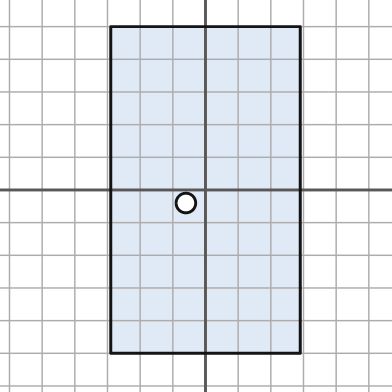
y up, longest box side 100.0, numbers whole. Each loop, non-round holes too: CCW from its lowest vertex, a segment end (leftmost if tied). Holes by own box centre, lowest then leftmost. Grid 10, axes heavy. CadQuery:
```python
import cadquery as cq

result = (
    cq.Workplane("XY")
    .moveTo(-29.0, -50.0)
    .lineTo(29.0, -50.0)
    .lineTo(29.0, 50.0)
    .lineTo(-29.0, 50.0)
    .close()
    .moveTo(-6.0, -4.0)
    .circle(3.0)
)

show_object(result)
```